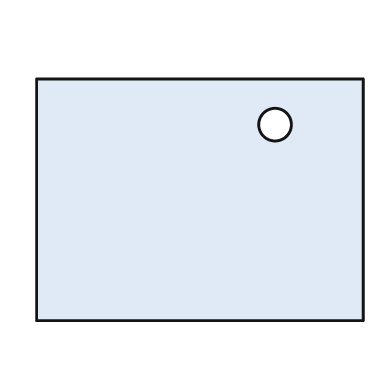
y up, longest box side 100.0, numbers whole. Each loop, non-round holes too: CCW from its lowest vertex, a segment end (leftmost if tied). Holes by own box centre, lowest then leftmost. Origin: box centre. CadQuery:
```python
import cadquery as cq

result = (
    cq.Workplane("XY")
    .moveTo(-50.0, -37.0)
    .lineTo(50.0, -37.0)
    .lineTo(50.0, 37.0)
    .lineTo(-50.0, 37.0)
    .close()
    .moveTo(23.0, 23.0)
    .circle(5.0)
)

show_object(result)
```